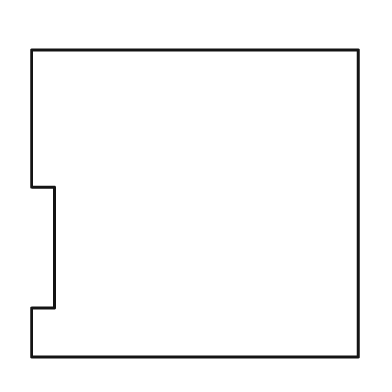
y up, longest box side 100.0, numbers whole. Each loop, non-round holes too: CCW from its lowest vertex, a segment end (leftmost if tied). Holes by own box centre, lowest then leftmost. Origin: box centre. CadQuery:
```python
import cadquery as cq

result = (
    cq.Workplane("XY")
    .moveTo(-50.0, -47.0)
    .lineTo(50.0, -47.0)
    .lineTo(50.0, 47.0)
    .lineTo(-50.0, 47.0)
    .lineTo(-50.0, 5.0)
    .lineTo(-43.0, 5.0)
    .lineTo(-43.0, -32.0)
    .lineTo(-50.0, -32.0)
    .close()
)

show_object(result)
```